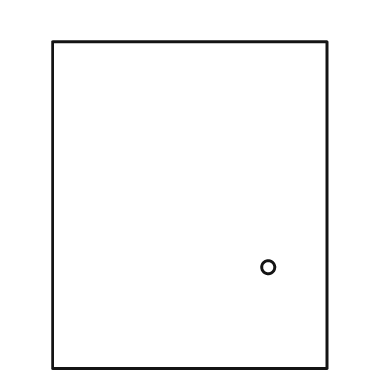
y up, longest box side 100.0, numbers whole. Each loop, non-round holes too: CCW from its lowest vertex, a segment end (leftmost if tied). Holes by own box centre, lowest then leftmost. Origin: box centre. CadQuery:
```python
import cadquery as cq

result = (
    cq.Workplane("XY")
    .moveTo(-42.0, -50.0)
    .lineTo(42.0, -50.0)
    .lineTo(42.0, 50.0)
    .lineTo(-42.0, 50.0)
    .close()
    .moveTo(24.0, -19.0)
    .circle(2.0)
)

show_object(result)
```